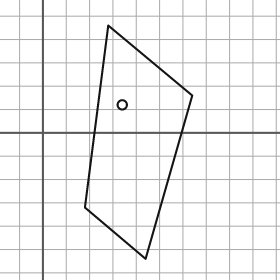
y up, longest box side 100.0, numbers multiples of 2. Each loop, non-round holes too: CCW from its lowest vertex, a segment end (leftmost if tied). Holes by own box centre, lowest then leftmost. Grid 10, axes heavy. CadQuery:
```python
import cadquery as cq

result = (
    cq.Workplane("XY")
    .moveTo(44.0, -54.0)
    .lineTo(64.0, 16.0)
    .lineTo(28.0, 46.0)
    .lineTo(18.0, -32.0)
    .close()
    .moveTo(34.0, 12.0)
    .circle(2.0)
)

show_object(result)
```